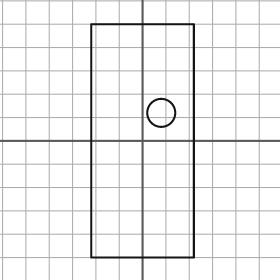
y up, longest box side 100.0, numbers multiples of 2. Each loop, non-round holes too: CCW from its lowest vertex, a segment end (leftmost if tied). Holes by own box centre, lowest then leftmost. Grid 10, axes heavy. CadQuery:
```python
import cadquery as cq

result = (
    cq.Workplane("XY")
    .moveTo(-22.0, -50.0)
    .lineTo(22.0, -50.0)
    .lineTo(22.0, 50.0)
    .lineTo(-22.0, 50.0)
    .close()
    .moveTo(8.0, 12.0)
    .circle(6.0)
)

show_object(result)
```